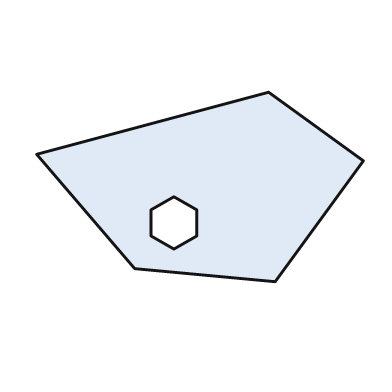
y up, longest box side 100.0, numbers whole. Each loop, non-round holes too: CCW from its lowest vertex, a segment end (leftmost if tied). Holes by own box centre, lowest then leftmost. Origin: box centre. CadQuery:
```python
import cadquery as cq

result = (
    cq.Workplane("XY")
    .moveTo(23.0, -29.0)
    .lineTo(50.0, 8.0)
    .lineTo(21.0, 29.0)
    .lineTo(-50.0, 10.0)
    .lineTo(-20.0, -25.0)
    .close()
    .moveTo(-8.0, -19.0)
    .lineTo(-1.0, -15.0)
    .lineTo(-1.0, -7.0)
    .lineTo(-8.0, -3.0)
    .lineTo(-15.0, -7.0)
    .lineTo(-15.0, -15.0)
    .close()
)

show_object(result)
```